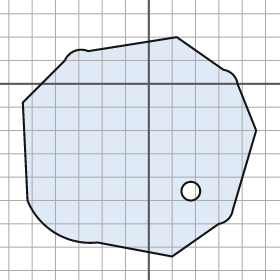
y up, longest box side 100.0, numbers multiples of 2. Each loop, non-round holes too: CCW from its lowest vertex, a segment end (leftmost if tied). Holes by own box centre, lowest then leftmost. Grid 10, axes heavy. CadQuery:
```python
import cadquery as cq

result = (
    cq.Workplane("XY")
    .moveTo(10.0, -74.0)
    .lineTo(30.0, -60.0)
    .threePointArc((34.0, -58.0), (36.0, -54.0))
    .lineTo(46.0, -20.0)
    .lineTo(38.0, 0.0)
    .threePointArc((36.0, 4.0), (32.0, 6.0))
    .lineTo(12.0, 20.0)
    .lineTo(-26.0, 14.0)
    .threePointArc((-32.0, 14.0), (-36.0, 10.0))
    .lineTo(-54.0, -8.0)
    .lineTo(-52.0, -50.0)
    .threePointArc((-40.0, -64.0), (-22.0, -68.0))
    .close()
    .moveTo(18.0, -46.0)
    .circle(4.0)
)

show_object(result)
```